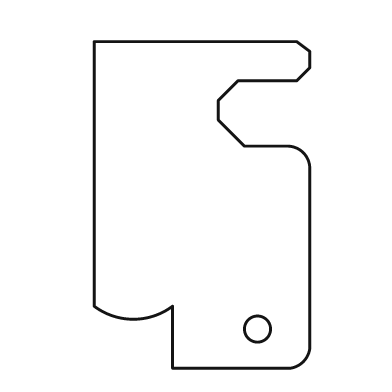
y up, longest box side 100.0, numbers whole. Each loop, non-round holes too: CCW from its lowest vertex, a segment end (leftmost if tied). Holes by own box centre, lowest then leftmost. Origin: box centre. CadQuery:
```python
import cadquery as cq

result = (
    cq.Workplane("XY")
    .moveTo(-9.0, -50.0)
    .lineTo(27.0, -50.0)
    .threePointArc((31.0, -48.0), (33.0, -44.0))
    .lineTo(33.0, 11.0)
    .threePointArc((31.0, 16.0), (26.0, 18.0))
    .lineTo(13.0, 18.0)
    .lineTo(5.0, 26.0)
    .lineTo(5.0, 32.0)
    .lineTo(11.0, 38.0)
    .lineTo(29.0, 38.0)
    .lineTo(33.0, 42.0)
    .lineTo(33.0, 47.0)
    .lineTo(29.0, 50.0)
    .lineTo(-33.0, 50.0)
    .lineTo(-33.0, -31.0)
    .threePointArc((-21.0, -35.0), (-9.0, -31.0))
    .close()
    .moveTo(17.0, -38.0)
    .circle(4.0)
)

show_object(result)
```